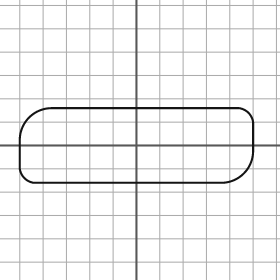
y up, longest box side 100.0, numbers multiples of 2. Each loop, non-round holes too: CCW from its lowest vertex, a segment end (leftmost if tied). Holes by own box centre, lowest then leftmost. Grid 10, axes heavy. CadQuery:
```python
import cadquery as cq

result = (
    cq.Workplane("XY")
    .moveTo(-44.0, -16.0)
    .lineTo(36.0, -16.0)
    .threePointArc((46.0, -12.0), (50.0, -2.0))
    .lineTo(50.0, 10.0)
    .threePointArc((48.0, 14.0), (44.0, 16.0))
    .lineTo(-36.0, 16.0)
    .threePointArc((-46.0, 12.0), (-50.0, 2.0))
    .lineTo(-50.0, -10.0)
    .threePointArc((-48.0, -14.0), (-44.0, -16.0))
    .close()
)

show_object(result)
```